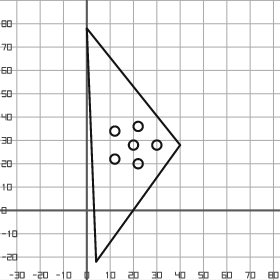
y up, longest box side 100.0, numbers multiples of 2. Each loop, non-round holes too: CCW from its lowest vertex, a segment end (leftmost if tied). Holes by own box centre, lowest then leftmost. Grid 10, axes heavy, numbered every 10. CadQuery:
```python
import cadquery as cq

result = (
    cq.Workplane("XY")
    .moveTo(4.0, -22.0)
    .lineTo(40.0, 28.0)
    .lineTo(0.0, 78.0)
    .close()
    .moveTo(22.0, 20.0)
    .circle(2.0)
    .moveTo(12.0, 22.0)
    .circle(2.0)
    .moveTo(20.0, 28.0)
    .circle(2.0)
    .moveTo(30.0, 28.0)
    .circle(2.0)
    .moveTo(12.0, 34.0)
    .circle(2.0)
    .moveTo(22.0, 36.0)
    .circle(2.0)
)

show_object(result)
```